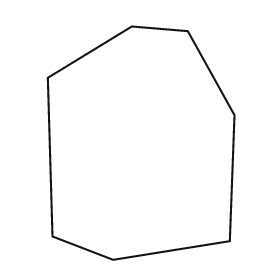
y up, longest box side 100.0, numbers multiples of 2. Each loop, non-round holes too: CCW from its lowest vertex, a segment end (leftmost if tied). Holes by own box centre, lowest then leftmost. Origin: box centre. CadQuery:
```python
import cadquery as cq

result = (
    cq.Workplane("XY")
    .moveTo(-12.0, -50.0)
    .lineTo(38.0, -42.0)
    .lineTo(40.0, 12.0)
    .lineTo(20.0, 48.0)
    .lineTo(-4.0, 50.0)
    .lineTo(-40.0, 28.0)
    .lineTo(-38.0, -40.0)
    .close()
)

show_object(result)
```